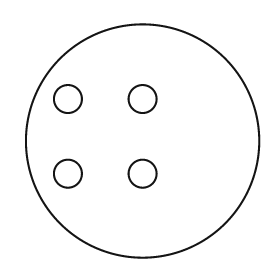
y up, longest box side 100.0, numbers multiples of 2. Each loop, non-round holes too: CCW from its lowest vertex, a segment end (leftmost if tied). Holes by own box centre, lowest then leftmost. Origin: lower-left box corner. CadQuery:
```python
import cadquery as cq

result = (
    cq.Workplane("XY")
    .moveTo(50.0, 50.0)
    .circle(50.0)
    .moveTo(18.0, 36.0)
    .circle(6.0)
    .moveTo(50.0, 36.0)
    .circle(6.0)
    .moveTo(18.0, 68.0)
    .circle(6.0)
    .moveTo(50.0, 68.0)
    .circle(6.0)
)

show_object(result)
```